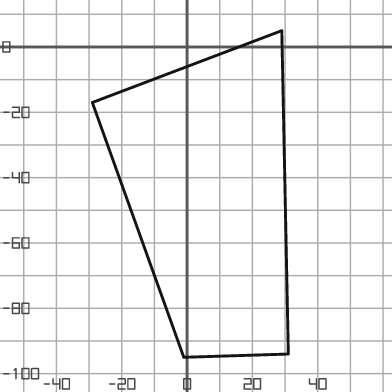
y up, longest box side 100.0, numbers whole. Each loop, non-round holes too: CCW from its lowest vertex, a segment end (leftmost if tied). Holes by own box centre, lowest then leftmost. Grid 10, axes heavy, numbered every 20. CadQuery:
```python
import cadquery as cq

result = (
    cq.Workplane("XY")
    .moveTo(-1.0, -95.0)
    .lineTo(31.0, -94.0)
    .lineTo(29.0, 5.0)
    .lineTo(-29.0, -17.0)
    .close()
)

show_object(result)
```